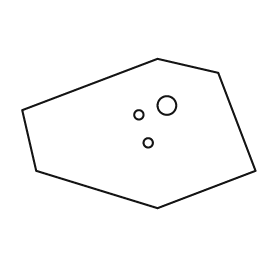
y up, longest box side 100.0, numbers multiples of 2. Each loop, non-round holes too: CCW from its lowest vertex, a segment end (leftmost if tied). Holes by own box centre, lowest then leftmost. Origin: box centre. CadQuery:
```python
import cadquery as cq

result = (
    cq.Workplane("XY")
    .moveTo(8.0, -32.0)
    .lineTo(50.0, -16.0)
    .lineTo(34.0, 26.0)
    .lineTo(8.0, 32.0)
    .lineTo(-50.0, 10.0)
    .lineTo(-44.0, -16.0)
    .close()
    .moveTo(4.0, -4.0)
    .circle(2.0)
    .moveTo(0.0, 8.0)
    .circle(2.0)
    .moveTo(12.0, 12.0)
    .circle(4.0)
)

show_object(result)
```